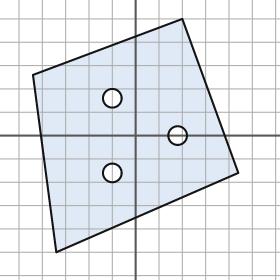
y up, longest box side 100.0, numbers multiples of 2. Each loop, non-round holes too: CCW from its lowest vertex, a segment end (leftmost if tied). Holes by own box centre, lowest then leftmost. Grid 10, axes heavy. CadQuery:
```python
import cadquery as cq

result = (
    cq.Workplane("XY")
    .moveTo(-34.0, -50.0)
    .lineTo(44.0, -16.0)
    .lineTo(20.0, 50.0)
    .lineTo(-44.0, 26.0)
    .close()
    .moveTo(-10.0, -16.0)
    .circle(4.0)
    .moveTo(18.0, 0.0)
    .circle(4.0)
    .moveTo(-10.0, 16.0)
    .circle(4.0)
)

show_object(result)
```